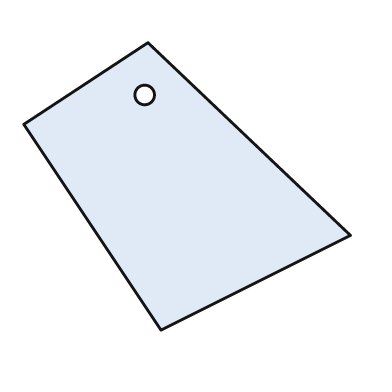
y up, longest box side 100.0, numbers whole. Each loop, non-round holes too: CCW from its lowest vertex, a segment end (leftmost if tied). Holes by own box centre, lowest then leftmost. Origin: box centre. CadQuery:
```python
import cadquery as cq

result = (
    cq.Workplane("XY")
    .moveTo(-8.0, -44.0)
    .lineTo(50.0, -15.0)
    .lineTo(-12.0, 44.0)
    .lineTo(-50.0, 19.0)
    .close()
    .moveTo(-13.0, 28.0)
    .circle(3.0)
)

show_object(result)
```